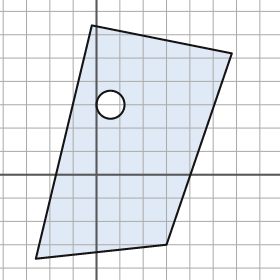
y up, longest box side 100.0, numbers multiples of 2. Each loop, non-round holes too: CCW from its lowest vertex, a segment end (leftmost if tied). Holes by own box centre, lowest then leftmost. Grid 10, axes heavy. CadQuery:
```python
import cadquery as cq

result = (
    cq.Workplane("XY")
    .moveTo(-26.0, -36.0)
    .lineTo(30.0, -30.0)
    .lineTo(58.0, 52.0)
    .lineTo(-2.0, 64.0)
    .close()
    .moveTo(6.0, 30.0)
    .circle(6.0)
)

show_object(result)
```